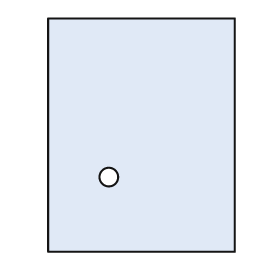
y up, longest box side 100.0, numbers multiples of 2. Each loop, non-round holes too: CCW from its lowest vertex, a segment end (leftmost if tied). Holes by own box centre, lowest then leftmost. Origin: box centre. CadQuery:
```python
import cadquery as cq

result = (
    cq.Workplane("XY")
    .moveTo(-40.0, -50.0)
    .lineTo(40.0, -50.0)
    .lineTo(40.0, 50.0)
    .lineTo(-40.0, 50.0)
    .close()
    .moveTo(-14.0, -18.0)
    .circle(4.0)
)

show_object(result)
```